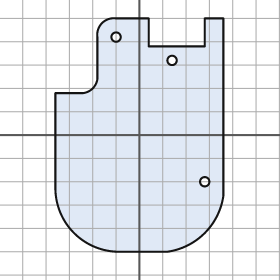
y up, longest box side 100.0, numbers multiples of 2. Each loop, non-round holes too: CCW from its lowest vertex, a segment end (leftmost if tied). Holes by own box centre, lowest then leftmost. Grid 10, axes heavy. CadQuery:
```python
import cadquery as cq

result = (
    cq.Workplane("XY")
    .moveTo(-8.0, -50.0)
    .lineTo(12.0, -50.0)
    .threePointArc((28.0, -42.0), (36.0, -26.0))
    .lineTo(36.0, 50.0)
    .lineTo(28.0, 50.0)
    .lineTo(28.0, 38.0)
    .lineTo(4.0, 38.0)
    .lineTo(4.0, 50.0)
    .lineTo(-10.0, 50.0)
    .threePointArc((-16.0, 48.0), (-18.0, 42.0))
    .lineTo(-18.0, 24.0)
    .threePointArc((-20.0, 20.0), (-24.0, 18.0))
    .lineTo(-36.0, 18.0)
    .lineTo(-36.0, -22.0)
    .threePointArc((-28.0, -42.0), (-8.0, -50.0))
    .close()
    .moveTo(28.0, -20.0)
    .circle(2.0)
    .moveTo(14.0, 32.0)
    .circle(2.0)
    .moveTo(-10.0, 42.0)
    .circle(2.0)
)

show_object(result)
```